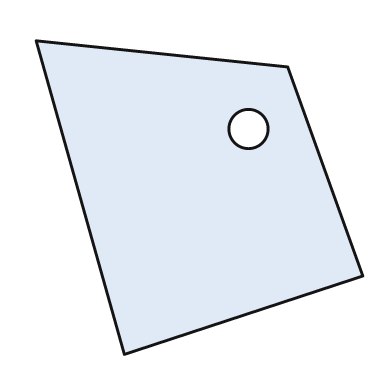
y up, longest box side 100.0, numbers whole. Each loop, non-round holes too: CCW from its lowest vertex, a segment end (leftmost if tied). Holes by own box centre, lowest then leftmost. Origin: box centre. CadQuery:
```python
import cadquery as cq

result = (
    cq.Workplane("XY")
    .moveTo(-23.0, -48.0)
    .lineTo(50.0, -24.0)
    .lineTo(27.0, 40.0)
    .lineTo(-50.0, 48.0)
    .close()
    .moveTo(15.0, 21.0)
    .circle(6.0)
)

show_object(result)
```